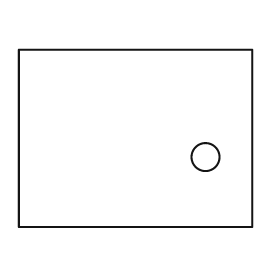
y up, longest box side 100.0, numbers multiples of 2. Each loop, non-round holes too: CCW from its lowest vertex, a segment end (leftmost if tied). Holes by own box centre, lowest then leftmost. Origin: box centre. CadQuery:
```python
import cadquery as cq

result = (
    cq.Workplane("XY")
    .moveTo(-50.0, -38.0)
    .lineTo(50.0, -38.0)
    .lineTo(50.0, 38.0)
    .lineTo(-50.0, 38.0)
    .close()
    .moveTo(30.0, -8.0)
    .circle(6.0)
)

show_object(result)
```